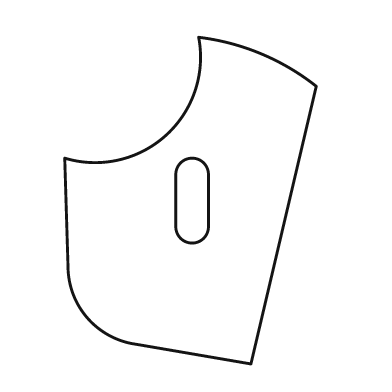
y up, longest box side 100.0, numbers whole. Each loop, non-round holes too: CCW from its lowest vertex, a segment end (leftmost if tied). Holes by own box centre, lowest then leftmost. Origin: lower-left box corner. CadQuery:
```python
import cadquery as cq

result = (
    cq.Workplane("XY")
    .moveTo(57.0, 0.0)
    .lineTo(77.0, 85.0)
    .threePointArc((60.0, 95.0), (41.0, 100.0))
    .threePointArc((31.0, 70.0), (0.0, 63.0))
    .lineTo(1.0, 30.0)
    .threePointArc((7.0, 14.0), (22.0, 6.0))
    .close()
    .moveTo(34.0, 42.0)
    .threePointArc((39.0, 37.0), (44.0, 42.0))
    .lineTo(44.0, 58.0)
    .threePointArc((39.0, 63.0), (34.0, 58.0))
    .close()
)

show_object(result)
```